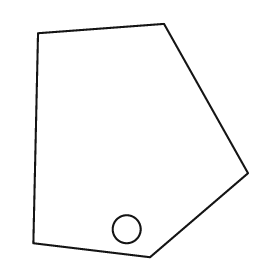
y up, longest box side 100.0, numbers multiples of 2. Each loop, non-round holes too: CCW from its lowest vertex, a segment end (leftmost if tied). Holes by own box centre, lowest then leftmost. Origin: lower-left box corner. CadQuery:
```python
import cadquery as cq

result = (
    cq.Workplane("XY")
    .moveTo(50.0, 0.0)
    .lineTo(92.0, 36.0)
    .lineTo(56.0, 100.0)
    .lineTo(2.0, 96.0)
    .lineTo(0.0, 6.0)
    .close()
    .moveTo(40.0, 12.0)
    .circle(6.0)
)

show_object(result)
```